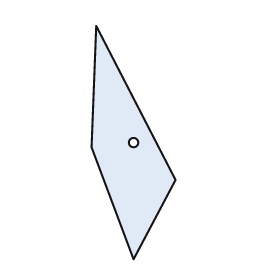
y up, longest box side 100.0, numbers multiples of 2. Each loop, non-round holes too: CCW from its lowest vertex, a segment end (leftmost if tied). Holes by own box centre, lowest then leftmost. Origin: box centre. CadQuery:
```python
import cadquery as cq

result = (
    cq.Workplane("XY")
    .moveTo(0.0, -50.0)
    .lineTo(18.0, -16.0)
    .lineTo(-16.0, 50.0)
    .lineTo(-18.0, -2.0)
    .close()
    .moveTo(0.0, 0.0)
    .circle(2.0)
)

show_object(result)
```